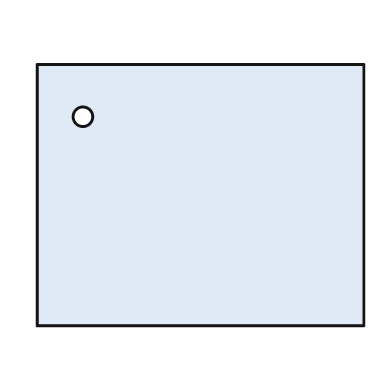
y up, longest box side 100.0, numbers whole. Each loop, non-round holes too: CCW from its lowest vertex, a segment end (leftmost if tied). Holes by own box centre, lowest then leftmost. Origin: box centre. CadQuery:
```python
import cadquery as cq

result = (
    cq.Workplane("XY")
    .moveTo(-50.0, -40.0)
    .lineTo(50.0, -40.0)
    .lineTo(50.0, 40.0)
    .lineTo(-50.0, 40.0)
    .close()
    .moveTo(-36.0, 24.0)
    .circle(3.0)
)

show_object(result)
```